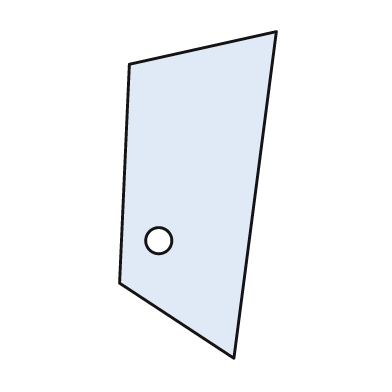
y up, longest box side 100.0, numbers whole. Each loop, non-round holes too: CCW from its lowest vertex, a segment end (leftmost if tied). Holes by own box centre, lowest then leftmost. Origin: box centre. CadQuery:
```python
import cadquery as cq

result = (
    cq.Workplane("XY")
    .moveTo(11.0, -50.0)
    .lineTo(24.0, 50.0)
    .lineTo(-21.0, 40.0)
    .lineTo(-24.0, -27.0)
    .close()
    .moveTo(-12.0, -14.0)
    .circle(4.0)
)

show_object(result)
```